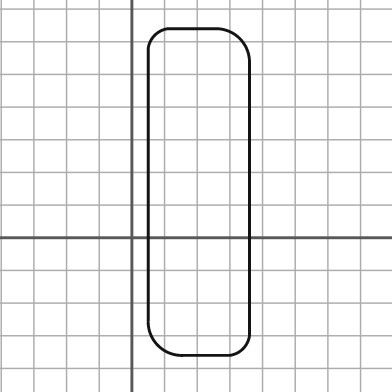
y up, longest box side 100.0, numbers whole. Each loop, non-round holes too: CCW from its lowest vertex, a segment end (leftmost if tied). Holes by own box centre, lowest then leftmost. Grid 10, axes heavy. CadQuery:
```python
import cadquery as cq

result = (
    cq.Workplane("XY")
    .moveTo(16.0, -36.0)
    .lineTo(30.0, -36.0)
    .threePointArc((34.0, -34.0), (36.0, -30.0))
    .lineTo(36.0, 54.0)
    .threePointArc((33.0, 61.0), (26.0, 64.0))
    .lineTo(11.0, 64.0)
    .threePointArc((7.0, 62.0), (5.0, 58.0))
    .lineTo(5.0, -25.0)
    .threePointArc((8.0, -33.0), (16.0, -36.0))
    .close()
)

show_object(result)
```